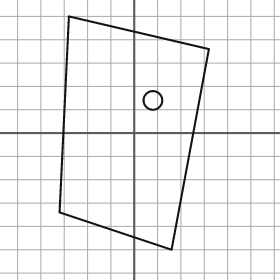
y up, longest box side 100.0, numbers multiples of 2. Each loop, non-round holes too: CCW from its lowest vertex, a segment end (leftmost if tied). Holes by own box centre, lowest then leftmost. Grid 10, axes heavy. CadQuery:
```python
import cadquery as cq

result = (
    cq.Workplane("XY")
    .moveTo(16.0, -50.0)
    .lineTo(32.0, 36.0)
    .lineTo(-28.0, 50.0)
    .lineTo(-32.0, -34.0)
    .close()
    .moveTo(8.0, 14.0)
    .circle(4.0)
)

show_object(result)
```